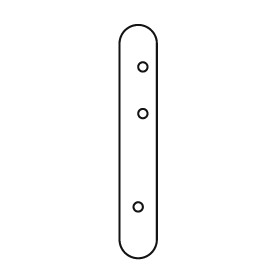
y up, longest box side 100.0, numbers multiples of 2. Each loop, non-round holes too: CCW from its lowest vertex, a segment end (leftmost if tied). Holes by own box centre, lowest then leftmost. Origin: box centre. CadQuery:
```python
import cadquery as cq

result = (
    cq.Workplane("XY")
    .moveTo(-8.0, -42.0)
    .threePointArc((0.0, -50.0), (8.0, -42.0))
    .lineTo(8.0, 42.0)
    .threePointArc((0.0, 50.0), (-8.0, 42.0))
    .close()
    .moveTo(0.0, -28.0)
    .circle(2.0)
    .moveTo(2.0, 12.0)
    .circle(2.0)
    .moveTo(2.0, 32.0)
    .circle(2.0)
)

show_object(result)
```